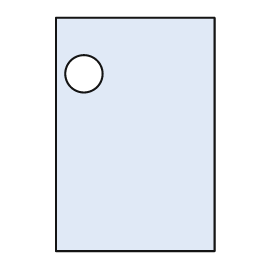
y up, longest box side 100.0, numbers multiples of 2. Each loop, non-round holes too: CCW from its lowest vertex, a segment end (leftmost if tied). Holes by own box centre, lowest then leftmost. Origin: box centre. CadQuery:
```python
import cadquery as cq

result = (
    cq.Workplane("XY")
    .moveTo(-34.0, -50.0)
    .lineTo(34.0, -50.0)
    .lineTo(34.0, 50.0)
    .lineTo(-34.0, 50.0)
    .close()
    .moveTo(-22.0, 26.0)
    .circle(8.0)
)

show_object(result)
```